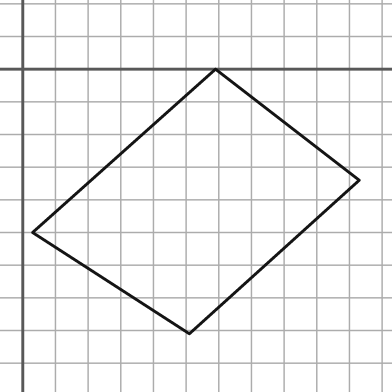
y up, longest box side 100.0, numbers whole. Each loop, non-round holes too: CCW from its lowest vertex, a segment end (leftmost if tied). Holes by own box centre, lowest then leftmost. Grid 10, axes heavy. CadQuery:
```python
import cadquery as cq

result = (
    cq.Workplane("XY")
    .moveTo(51.0, -81.0)
    .lineTo(103.0, -34.0)
    .lineTo(59.0, 0.0)
    .lineTo(3.0, -50.0)
    .close()
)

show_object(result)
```